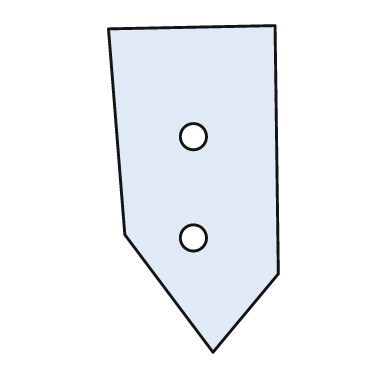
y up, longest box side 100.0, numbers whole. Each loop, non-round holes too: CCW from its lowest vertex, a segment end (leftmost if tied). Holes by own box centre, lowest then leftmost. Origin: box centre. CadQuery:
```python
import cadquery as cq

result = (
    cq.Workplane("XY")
    .moveTo(6.0, -50.0)
    .lineTo(26.0, -26.0)
    .lineTo(25.0, 50.0)
    .lineTo(-26.0, 49.0)
    .lineTo(-21.0, -14.0)
    .close()
    .moveTo(0.0, -15.0)
    .circle(4.0)
    .moveTo(0.0, 16.0)
    .circle(4.0)
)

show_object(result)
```